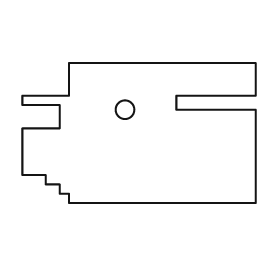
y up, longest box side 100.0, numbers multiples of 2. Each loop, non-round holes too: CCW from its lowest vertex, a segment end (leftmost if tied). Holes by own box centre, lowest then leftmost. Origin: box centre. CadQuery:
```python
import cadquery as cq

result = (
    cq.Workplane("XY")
    .moveTo(-30.0, -30.0)
    .lineTo(50.0, -30.0)
    .lineTo(50.0, 10.0)
    .lineTo(16.0, 10.0)
    .lineTo(16.0, 16.0)
    .lineTo(50.0, 16.0)
    .lineTo(50.0, 30.0)
    .lineTo(-30.0, 30.0)
    .lineTo(-30.0, 16.0)
    .lineTo(-50.0, 16.0)
    .lineTo(-50.0, 12.0)
    .lineTo(-34.0, 12.0)
    .lineTo(-34.0, 2.0)
    .lineTo(-50.0, 2.0)
    .lineTo(-50.0, -18.0)
    .lineTo(-40.0, -18.0)
    .lineTo(-40.0, -22.0)
    .lineTo(-34.0, -22.0)
    .lineTo(-34.0, -26.0)
    .lineTo(-30.0, -26.0)
    .close()
    .moveTo(-6.0, 10.0)
    .circle(4.0)
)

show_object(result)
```